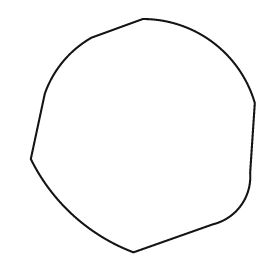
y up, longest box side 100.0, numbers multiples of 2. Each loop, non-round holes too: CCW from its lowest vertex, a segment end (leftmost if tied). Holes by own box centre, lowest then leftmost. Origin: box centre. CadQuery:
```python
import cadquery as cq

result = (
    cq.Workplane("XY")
    .moveTo(-4.0, -50.0)
    .lineTo(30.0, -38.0)
    .threePointArc((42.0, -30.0), (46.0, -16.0))
    .lineTo(48.0, 14.0)
    .threePointArc((30.0, 40.0), (0.0, 50.0))
    .lineTo(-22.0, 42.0)
    .threePointArc((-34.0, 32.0), (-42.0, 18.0))
    .lineTo(-48.0, -10.0)
    .threePointArc((-30.0, -34.0), (-4.0, -50.0))
    .close()
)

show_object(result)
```